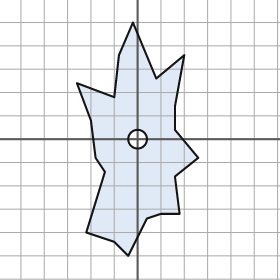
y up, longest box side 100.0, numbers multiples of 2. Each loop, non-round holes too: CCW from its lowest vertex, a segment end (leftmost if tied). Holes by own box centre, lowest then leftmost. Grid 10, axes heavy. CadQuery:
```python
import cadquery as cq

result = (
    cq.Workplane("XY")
    .moveTo(-4.0, -50.0)
    .lineTo(4.0, -34.0)
    .lineTo(10.0, -32.0)
    .lineTo(18.0, -32.0)
    .lineTo(16.0, -16.0)
    .lineTo(26.0, -8.0)
    .lineTo(16.0, 4.0)
    .lineTo(16.0, 14.0)
    .lineTo(20.0, 36.0)
    .lineTo(8.0, 26.0)
    .lineTo(-2.0, 50.0)
    .lineTo(-8.0, 36.0)
    .lineTo(-10.0, 18.0)
    .lineTo(-26.0, 24.0)
    .lineTo(-20.0, 8.0)
    .lineTo(-18.0, -8.0)
    .lineTo(-14.0, -14.0)
    .lineTo(-22.0, -40.0)
    .lineTo(-10.0, -44.0)
    .close()
    .moveTo(0.0, 0.0)
    .circle(4.0)
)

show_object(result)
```